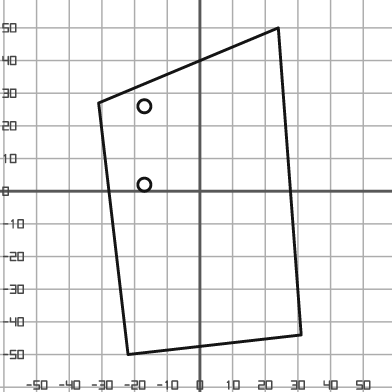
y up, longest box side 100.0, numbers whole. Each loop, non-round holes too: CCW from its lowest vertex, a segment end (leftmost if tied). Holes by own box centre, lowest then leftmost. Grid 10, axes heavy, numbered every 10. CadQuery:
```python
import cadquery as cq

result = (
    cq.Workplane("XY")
    .moveTo(-22.0, -50.0)
    .lineTo(31.0, -44.0)
    .lineTo(24.0, 50.0)
    .lineTo(-31.0, 27.0)
    .close()
    .moveTo(-17.0, 2.0)
    .circle(2.0)
    .moveTo(-17.0, 26.0)
    .circle(2.0)
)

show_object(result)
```